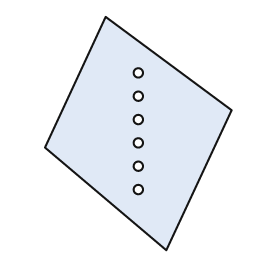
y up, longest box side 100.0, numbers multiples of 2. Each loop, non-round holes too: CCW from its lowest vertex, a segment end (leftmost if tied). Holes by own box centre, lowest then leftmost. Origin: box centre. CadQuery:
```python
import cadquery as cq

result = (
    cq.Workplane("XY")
    .moveTo(12.0, -50.0)
    .lineTo(40.0, 10.0)
    .lineTo(-14.0, 50.0)
    .lineTo(-40.0, -6.0)
    .close()
    .moveTo(0.0, -24.0)
    .circle(2.0)
    .moveTo(0.0, -14.0)
    .circle(2.0)
    .moveTo(0.0, -4.0)
    .circle(2.0)
    .moveTo(0.0, 6.0)
    .circle(2.0)
    .moveTo(0.0, 16.0)
    .circle(2.0)
    .moveTo(0.0, 26.0)
    .circle(2.0)
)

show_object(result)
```